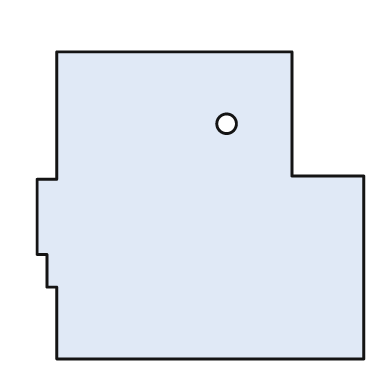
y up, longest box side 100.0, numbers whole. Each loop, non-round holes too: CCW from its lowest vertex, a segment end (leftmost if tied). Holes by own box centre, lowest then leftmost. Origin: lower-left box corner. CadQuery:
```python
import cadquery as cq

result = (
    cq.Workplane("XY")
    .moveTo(6.0, 0.0)
    .lineTo(100.0, 0.0)
    .lineTo(100.0, 56.0)
    .lineTo(78.0, 56.0)
    .lineTo(78.0, 94.0)
    .lineTo(6.0, 94.0)
    .lineTo(6.0, 55.0)
    .lineTo(0.0, 55.0)
    .lineTo(0.0, 32.0)
    .lineTo(3.0, 32.0)
    .lineTo(3.0, 22.0)
    .lineTo(6.0, 22.0)
    .close()
    .moveTo(58.0, 72.0)
    .circle(3.0)
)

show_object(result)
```